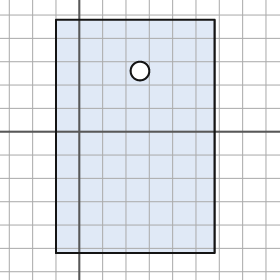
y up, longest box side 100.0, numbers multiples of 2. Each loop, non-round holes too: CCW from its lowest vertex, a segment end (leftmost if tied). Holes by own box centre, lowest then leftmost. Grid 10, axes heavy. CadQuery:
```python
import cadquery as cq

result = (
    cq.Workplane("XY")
    .moveTo(-10.0, -52.0)
    .lineTo(58.0, -52.0)
    .lineTo(58.0, 48.0)
    .lineTo(-10.0, 48.0)
    .close()
    .moveTo(26.0, 26.0)
    .circle(4.0)
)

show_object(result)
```